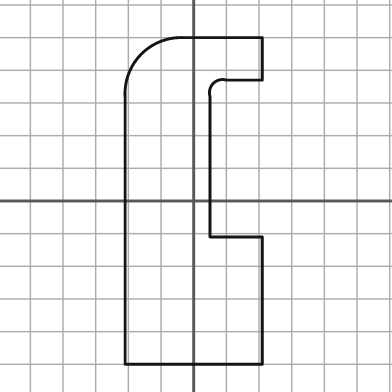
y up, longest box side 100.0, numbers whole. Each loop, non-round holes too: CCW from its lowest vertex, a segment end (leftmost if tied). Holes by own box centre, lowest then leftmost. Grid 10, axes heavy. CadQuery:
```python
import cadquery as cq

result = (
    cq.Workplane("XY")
    .moveTo(-21.0, -50.0)
    .lineTo(21.0, -50.0)
    .lineTo(21.0, -11.0)
    .lineTo(5.0, -11.0)
    .lineTo(5.0, 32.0)
    .threePointArc((6.0, 36.0), (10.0, 37.0))
    .lineTo(21.0, 37.0)
    .lineTo(21.0, 50.0)
    .lineTo(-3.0, 50.0)
    .threePointArc((-16.0, 45.0), (-21.0, 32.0))
    .close()
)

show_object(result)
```